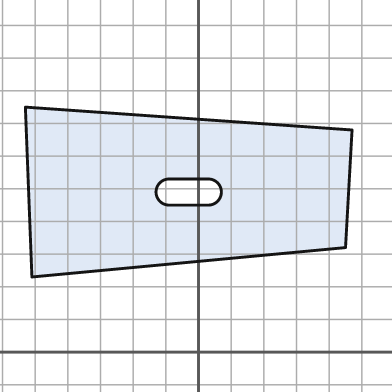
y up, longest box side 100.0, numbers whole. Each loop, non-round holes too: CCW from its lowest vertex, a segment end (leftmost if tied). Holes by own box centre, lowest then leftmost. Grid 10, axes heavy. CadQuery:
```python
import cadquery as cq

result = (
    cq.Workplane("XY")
    .moveTo(-51.0, 23.0)
    .lineTo(45.0, 32.0)
    .lineTo(47.0, 68.0)
    .lineTo(-53.0, 75.0)
    .close()
    .moveTo(-9.0, 45.0)
    .lineTo(3.0, 45.0)
    .threePointArc((7.0, 49.0), (3.0, 53.0))
    .lineTo(-9.0, 53.0)
    .threePointArc((-13.0, 49.0), (-9.0, 45.0))
    .close()
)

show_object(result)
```